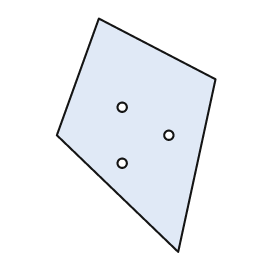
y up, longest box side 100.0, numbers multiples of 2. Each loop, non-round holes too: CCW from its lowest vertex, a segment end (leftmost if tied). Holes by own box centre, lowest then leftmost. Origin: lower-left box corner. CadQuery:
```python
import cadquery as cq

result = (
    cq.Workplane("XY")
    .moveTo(52.0, 0.0)
    .lineTo(68.0, 74.0)
    .lineTo(18.0, 100.0)
    .lineTo(0.0, 50.0)
    .close()
    .moveTo(28.0, 38.0)
    .circle(2.0)
    .moveTo(48.0, 50.0)
    .circle(2.0)
    .moveTo(28.0, 62.0)
    .circle(2.0)
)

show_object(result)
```